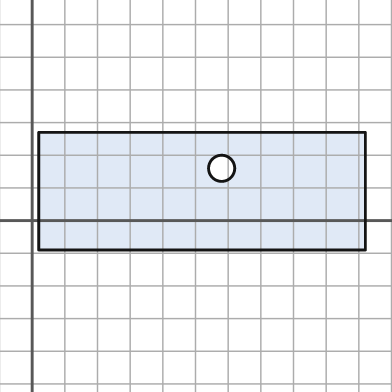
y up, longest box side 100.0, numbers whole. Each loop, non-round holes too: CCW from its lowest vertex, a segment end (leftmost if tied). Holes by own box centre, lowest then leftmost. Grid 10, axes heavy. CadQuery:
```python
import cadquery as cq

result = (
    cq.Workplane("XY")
    .moveTo(2.0, -9.0)
    .lineTo(102.0, -9.0)
    .lineTo(102.0, 27.0)
    .lineTo(2.0, 27.0)
    .close()
    .moveTo(58.0, 16.0)
    .circle(4.0)
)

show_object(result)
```